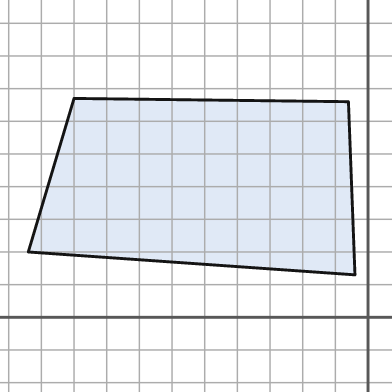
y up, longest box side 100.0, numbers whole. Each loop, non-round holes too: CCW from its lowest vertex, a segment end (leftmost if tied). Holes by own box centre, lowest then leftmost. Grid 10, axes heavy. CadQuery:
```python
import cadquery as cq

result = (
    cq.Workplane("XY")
    .moveTo(-4.0, 13.0)
    .lineTo(-6.0, 66.0)
    .lineTo(-90.0, 67.0)
    .lineTo(-104.0, 20.0)
    .close()
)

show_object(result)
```